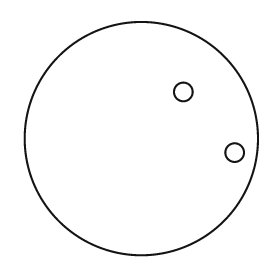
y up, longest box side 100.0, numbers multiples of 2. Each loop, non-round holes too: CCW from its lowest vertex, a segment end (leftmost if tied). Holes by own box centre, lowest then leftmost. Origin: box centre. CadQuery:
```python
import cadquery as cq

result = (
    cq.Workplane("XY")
    .moveTo(0.0, 0.0)
    .circle(50.0)
    .moveTo(40.0, -6.0)
    .circle(4.0)
    .moveTo(18.0, 20.0)
    .circle(4.0)
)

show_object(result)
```